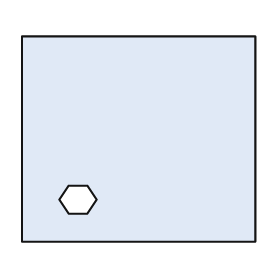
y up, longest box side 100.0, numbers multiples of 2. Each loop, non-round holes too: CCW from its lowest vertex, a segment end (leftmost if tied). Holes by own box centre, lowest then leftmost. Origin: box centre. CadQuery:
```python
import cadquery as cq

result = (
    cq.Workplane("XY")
    .moveTo(-50.0, -44.0)
    .lineTo(50.0, -44.0)
    .lineTo(50.0, 44.0)
    .lineTo(-50.0, 44.0)
    .close()
    .moveTo(-30.0, -32.0)
    .lineTo(-22.0, -32.0)
    .lineTo(-18.0, -26.0)
    .lineTo(-22.0, -20.0)
    .lineTo(-30.0, -20.0)
    .lineTo(-34.0, -26.0)
    .close()
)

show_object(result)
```